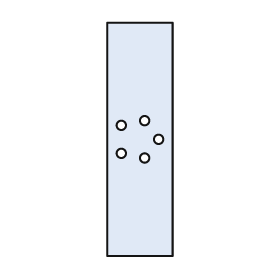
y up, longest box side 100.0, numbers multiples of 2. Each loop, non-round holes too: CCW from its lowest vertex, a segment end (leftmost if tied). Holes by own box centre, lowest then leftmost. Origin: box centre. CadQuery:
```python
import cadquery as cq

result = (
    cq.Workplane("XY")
    .moveTo(-14.0, -50.0)
    .lineTo(14.0, -50.0)
    .lineTo(14.0, 50.0)
    .lineTo(-14.0, 50.0)
    .close()
    .moveTo(2.0, -8.0)
    .circle(2.0)
    .moveTo(-8.0, -6.0)
    .circle(2.0)
    .moveTo(8.0, 0.0)
    .circle(2.0)
    .moveTo(-8.0, 6.0)
    .circle(2.0)
    .moveTo(2.0, 8.0)
    .circle(2.0)
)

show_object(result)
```